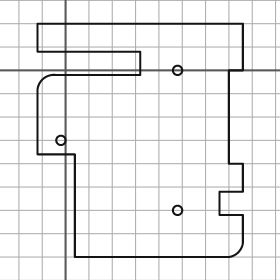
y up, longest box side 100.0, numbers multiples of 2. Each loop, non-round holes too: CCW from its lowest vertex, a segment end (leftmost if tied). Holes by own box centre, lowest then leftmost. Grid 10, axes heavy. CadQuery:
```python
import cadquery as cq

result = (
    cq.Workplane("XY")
    .moveTo(4.0, -80.0)
    .lineTo(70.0, -80.0)
    .threePointArc((74.0, -78.0), (76.0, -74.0))
    .lineTo(76.0, -62.0)
    .lineTo(66.0, -62.0)
    .lineTo(66.0, -52.0)
    .lineTo(76.0, -52.0)
    .lineTo(76.0, -40.0)
    .lineTo(70.0, -40.0)
    .lineTo(70.0, 0.0)
    .lineTo(76.0, 0.0)
    .lineTo(76.0, 20.0)
    .lineTo(-12.0, 20.0)
    .lineTo(-12.0, 8.0)
    .lineTo(32.0, 8.0)
    .lineTo(32.0, -2.0)
    .lineTo(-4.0, -2.0)
    .threePointArc((-10.0, -4.0), (-12.0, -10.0))
    .lineTo(-12.0, -36.0)
    .lineTo(4.0, -36.0)
    .close()
    .moveTo(48.0, -60.0)
    .circle(2.0)
    .moveTo(-2.0, -30.0)
    .circle(2.0)
    .moveTo(48.0, 0.0)
    .circle(2.0)
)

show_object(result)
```